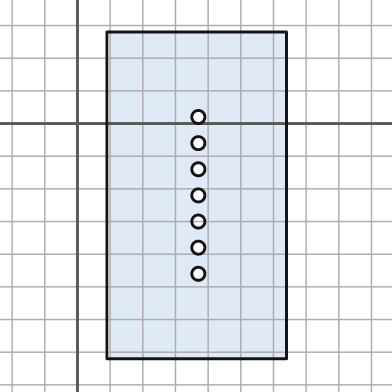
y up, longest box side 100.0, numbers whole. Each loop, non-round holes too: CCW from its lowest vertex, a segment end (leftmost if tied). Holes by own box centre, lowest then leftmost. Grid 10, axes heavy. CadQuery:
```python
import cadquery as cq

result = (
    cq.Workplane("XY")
    .moveTo(9.0, -72.0)
    .lineTo(64.0, -72.0)
    .lineTo(64.0, 28.0)
    .lineTo(9.0, 28.0)
    .close()
    .moveTo(37.0, -46.0)
    .circle(2.0)
    .moveTo(37.0, -38.0)
    .circle(2.0)
    .moveTo(37.0, -30.0)
    .circle(2.0)
    .moveTo(37.0, -22.0)
    .circle(2.0)
    .moveTo(37.0, -14.0)
    .circle(2.0)
    .moveTo(37.0, -6.0)
    .circle(2.0)
    .moveTo(37.0, 2.0)
    .circle(2.0)
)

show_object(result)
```